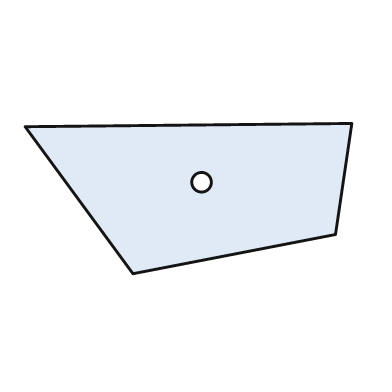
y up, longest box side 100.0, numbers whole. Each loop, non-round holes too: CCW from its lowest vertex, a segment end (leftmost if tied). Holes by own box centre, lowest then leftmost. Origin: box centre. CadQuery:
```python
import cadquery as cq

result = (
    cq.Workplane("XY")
    .moveTo(-17.0, -23.0)
    .lineTo(45.0, -11.0)
    .lineTo(50.0, 23.0)
    .lineTo(-50.0, 22.0)
    .close()
    .moveTo(4.0, 5.0)
    .circle(3.0)
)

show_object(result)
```